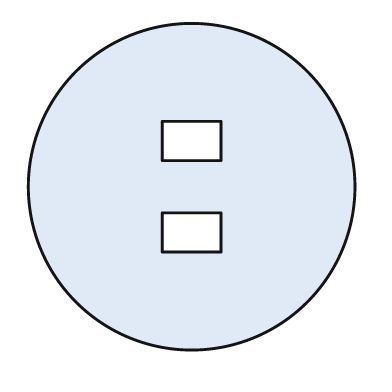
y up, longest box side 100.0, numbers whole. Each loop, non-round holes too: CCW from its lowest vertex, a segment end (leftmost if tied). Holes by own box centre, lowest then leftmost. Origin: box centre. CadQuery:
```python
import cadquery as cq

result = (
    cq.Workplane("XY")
    .moveTo(0.0, 0.0)
    .circle(50.0)
    .moveTo(-9.0, -20.0)
    .lineTo(9.0, -20.0)
    .lineTo(9.0, -8.0)
    .lineTo(-9.0, -8.0)
    .close()
    .moveTo(-9.0, 8.0)
    .lineTo(9.0, 8.0)
    .lineTo(9.0, 20.0)
    .lineTo(-9.0, 20.0)
    .close()
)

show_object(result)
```